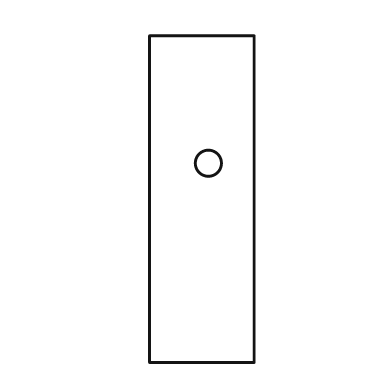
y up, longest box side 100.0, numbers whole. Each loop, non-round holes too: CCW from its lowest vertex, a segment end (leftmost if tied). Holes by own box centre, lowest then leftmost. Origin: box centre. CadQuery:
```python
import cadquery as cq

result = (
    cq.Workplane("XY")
    .moveTo(-16.0, -50.0)
    .lineTo(16.0, -50.0)
    .lineTo(16.0, 50.0)
    .lineTo(-16.0, 50.0)
    .close()
    .moveTo(2.0, 11.0)
    .circle(4.0)
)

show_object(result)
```